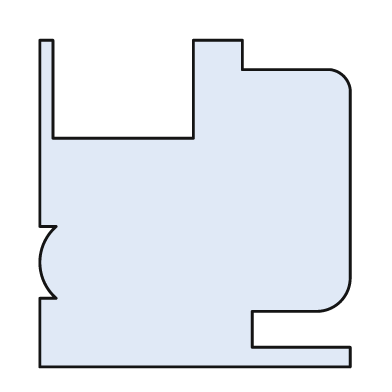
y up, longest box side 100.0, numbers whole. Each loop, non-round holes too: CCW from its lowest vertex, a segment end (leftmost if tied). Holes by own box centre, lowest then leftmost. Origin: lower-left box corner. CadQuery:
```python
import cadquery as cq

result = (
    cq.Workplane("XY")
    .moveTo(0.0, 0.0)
    .lineTo(95.0, 0.0)
    .lineTo(95.0, 6.0)
    .lineTo(65.0, 6.0)
    .lineTo(65.0, 17.0)
    .lineTo(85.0, 17.0)
    .threePointArc((92.0, 20.0), (95.0, 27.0))
    .lineTo(95.0, 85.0)
    .threePointArc((93.0, 89.0), (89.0, 91.0))
    .lineTo(62.0, 91.0)
    .lineTo(62.0, 100.0)
    .lineTo(47.0, 100.0)
    .lineTo(47.0, 70.0)
    .lineTo(4.0, 70.0)
    .lineTo(4.0, 100.0)
    .lineTo(0.0, 100.0)
    .lineTo(0.0, 43.0)
    .lineTo(5.0, 43.0)
    .threePointArc((0.0, 32.0), (5.0, 21.0))
    .lineTo(0.0, 21.0)
    .close()
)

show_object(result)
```